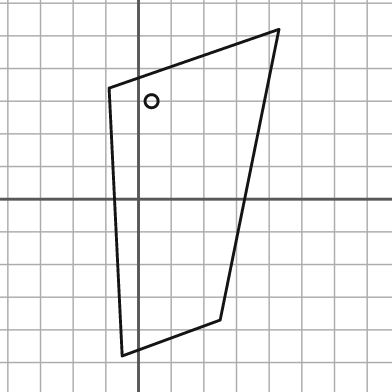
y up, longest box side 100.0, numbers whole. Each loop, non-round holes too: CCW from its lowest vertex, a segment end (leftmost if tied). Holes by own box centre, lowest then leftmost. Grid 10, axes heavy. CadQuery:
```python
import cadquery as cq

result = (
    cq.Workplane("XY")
    .moveTo(-5.0, -48.0)
    .lineTo(25.0, -37.0)
    .lineTo(43.0, 52.0)
    .lineTo(-9.0, 34.0)
    .close()
    .moveTo(4.0, 30.0)
    .circle(2.0)
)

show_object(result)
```